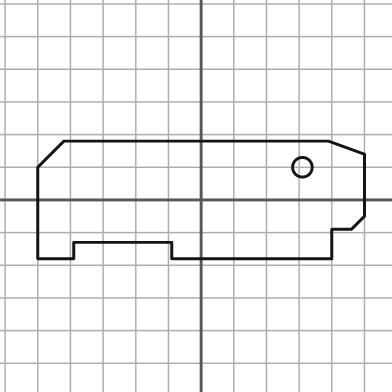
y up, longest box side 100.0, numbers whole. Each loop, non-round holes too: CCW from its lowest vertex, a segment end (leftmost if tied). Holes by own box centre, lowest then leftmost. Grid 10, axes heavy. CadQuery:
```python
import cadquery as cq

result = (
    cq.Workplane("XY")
    .moveTo(-50.0, -18.0)
    .lineTo(-39.0, -18.0)
    .lineTo(-39.0, -13.0)
    .lineTo(-9.0, -13.0)
    .lineTo(-9.0, -18.0)
    .lineTo(40.0, -18.0)
    .lineTo(40.0, -9.0)
    .lineTo(46.0, -9.0)
    .lineTo(50.0, -5.0)
    .lineTo(50.0, 14.0)
    .lineTo(39.0, 18.0)
    .lineTo(-42.0, 18.0)
    .lineTo(-50.0, 10.0)
    .close()
    .moveTo(31.0, 10.0)
    .circle(3.0)
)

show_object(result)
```